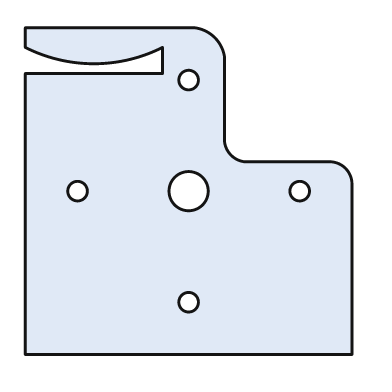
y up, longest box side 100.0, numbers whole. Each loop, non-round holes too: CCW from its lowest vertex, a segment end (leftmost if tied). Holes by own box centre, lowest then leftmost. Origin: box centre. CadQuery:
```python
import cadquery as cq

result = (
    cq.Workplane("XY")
    .moveTo(-50.0, -50.0)
    .lineTo(50.0, -50.0)
    .lineTo(50.0, 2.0)
    .threePointArc((48.0, 7.0), (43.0, 9.0))
    .lineTo(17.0, 9.0)
    .threePointArc((13.0, 11.0), (11.0, 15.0))
    .lineTo(11.0, 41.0)
    .threePointArc((8.0, 47.0), (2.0, 50.0))
    .lineTo(-50.0, 50.0)
    .lineTo(-50.0, 44.0)
    .threePointArc((-29.0, 39.0), (-8.0, 44.0))
    .lineTo(-8.0, 36.0)
    .lineTo(-50.0, 36.0)
    .close()
    .moveTo(0.0, -34.0)
    .circle(3.0)
    .moveTo(-34.0, 0.0)
    .circle(3.0)
    .moveTo(0.0, 0.0)
    .circle(6.0)
    .moveTo(34.0, 0.0)
    .circle(3.0)
    .moveTo(0.0, 34.0)
    .circle(3.0)
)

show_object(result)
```